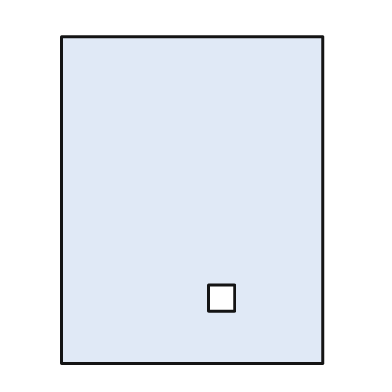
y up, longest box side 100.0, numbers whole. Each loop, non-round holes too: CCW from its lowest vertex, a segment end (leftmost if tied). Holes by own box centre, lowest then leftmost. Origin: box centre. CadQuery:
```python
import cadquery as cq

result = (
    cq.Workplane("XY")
    .moveTo(-40.0, -50.0)
    .lineTo(40.0, -50.0)
    .lineTo(40.0, 50.0)
    .lineTo(-40.0, 50.0)
    .close()
    .moveTo(5.0, -34.0)
    .lineTo(13.0, -34.0)
    .lineTo(13.0, -26.0)
    .lineTo(5.0, -26.0)
    .close()
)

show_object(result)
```